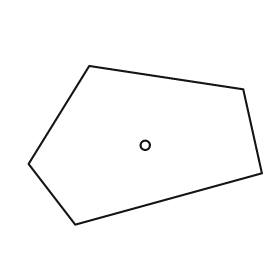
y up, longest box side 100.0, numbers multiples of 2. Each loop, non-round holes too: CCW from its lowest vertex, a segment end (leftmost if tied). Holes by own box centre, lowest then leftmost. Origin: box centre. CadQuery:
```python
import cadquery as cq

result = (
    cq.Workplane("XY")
    .moveTo(-30.0, -34.0)
    .lineTo(50.0, -12.0)
    .lineTo(42.0, 24.0)
    .lineTo(-24.0, 34.0)
    .lineTo(-50.0, -8.0)
    .close()
    .moveTo(0.0, 0.0)
    .circle(2.0)
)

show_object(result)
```